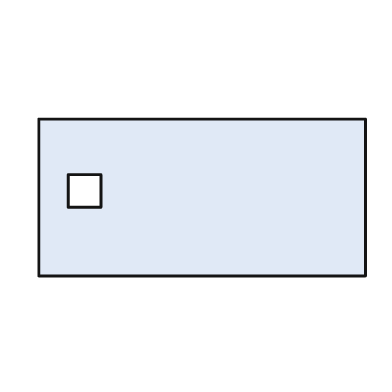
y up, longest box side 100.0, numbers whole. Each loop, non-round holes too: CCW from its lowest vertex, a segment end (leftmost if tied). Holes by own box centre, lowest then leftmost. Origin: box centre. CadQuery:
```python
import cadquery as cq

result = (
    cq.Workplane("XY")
    .moveTo(-50.0, -24.0)
    .lineTo(50.0, -24.0)
    .lineTo(50.0, 24.0)
    .lineTo(-50.0, 24.0)
    .close()
    .moveTo(-41.0, -3.0)
    .lineTo(-31.0, -3.0)
    .lineTo(-31.0, 7.0)
    .lineTo(-41.0, 7.0)
    .close()
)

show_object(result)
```